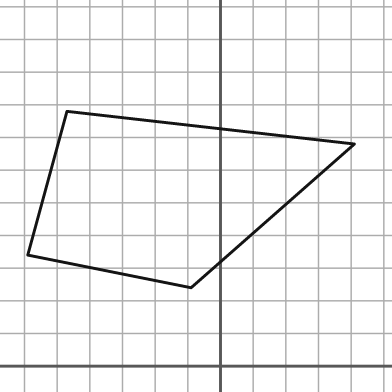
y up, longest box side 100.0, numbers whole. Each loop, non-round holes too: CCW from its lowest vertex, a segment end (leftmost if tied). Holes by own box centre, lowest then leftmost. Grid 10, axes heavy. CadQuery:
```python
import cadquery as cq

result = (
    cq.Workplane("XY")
    .moveTo(-9.0, 24.0)
    .lineTo(41.0, 68.0)
    .lineTo(-47.0, 78.0)
    .lineTo(-59.0, 34.0)
    .close()
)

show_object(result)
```